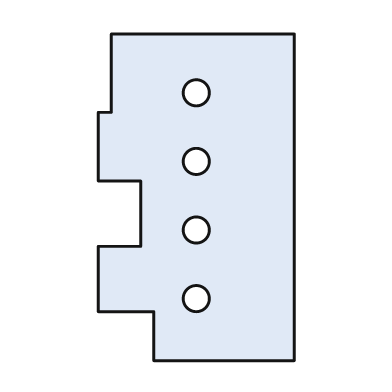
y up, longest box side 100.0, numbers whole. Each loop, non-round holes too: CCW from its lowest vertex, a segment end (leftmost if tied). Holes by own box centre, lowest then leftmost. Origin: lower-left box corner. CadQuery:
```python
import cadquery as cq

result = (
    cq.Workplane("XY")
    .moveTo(17.0, 0.0)
    .lineTo(60.0, 0.0)
    .lineTo(60.0, 100.0)
    .lineTo(4.0, 100.0)
    .lineTo(4.0, 76.0)
    .lineTo(0.0, 76.0)
    .lineTo(0.0, 55.0)
    .lineTo(13.0, 55.0)
    .lineTo(13.0, 35.0)
    .lineTo(0.0, 35.0)
    .lineTo(0.0, 15.0)
    .lineTo(17.0, 15.0)
    .close()
    .moveTo(30.0, 19.0)
    .circle(4.0)
    .moveTo(30.0, 40.0)
    .circle(4.0)
    .moveTo(30.0, 61.0)
    .circle(4.0)
    .moveTo(30.0, 82.0)
    .circle(4.0)
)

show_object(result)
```